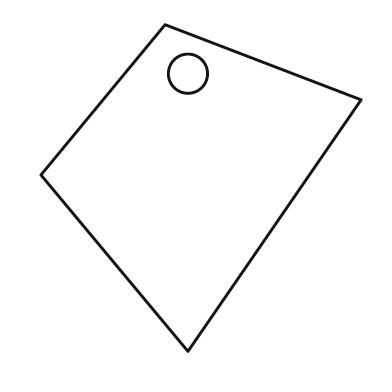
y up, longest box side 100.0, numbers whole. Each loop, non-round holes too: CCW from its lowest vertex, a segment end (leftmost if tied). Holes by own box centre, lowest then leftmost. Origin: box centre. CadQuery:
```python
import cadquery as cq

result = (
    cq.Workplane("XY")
    .moveTo(-4.0, -50.0)
    .lineTo(49.0, 27.0)
    .lineTo(-11.0, 50.0)
    .lineTo(-49.0, 4.0)
    .close()
    .moveTo(-4.0, 35.0)
    .circle(6.0)
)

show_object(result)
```